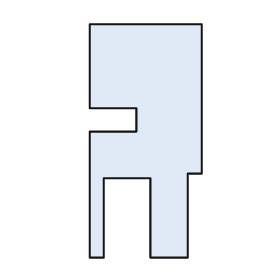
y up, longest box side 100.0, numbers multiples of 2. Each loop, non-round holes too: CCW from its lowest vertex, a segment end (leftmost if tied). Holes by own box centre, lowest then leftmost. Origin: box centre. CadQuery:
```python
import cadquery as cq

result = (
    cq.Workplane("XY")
    .moveTo(-24.0, -50.0)
    .lineTo(-18.0, -50.0)
    .lineTo(-18.0, -16.0)
    .lineTo(2.0, -16.0)
    .lineTo(2.0, -50.0)
    .lineTo(18.0, -50.0)
    .lineTo(18.0, -14.0)
    .lineTo(24.0, -14.0)
    .lineTo(24.0, 50.0)
    .lineTo(-24.0, 50.0)
    .lineTo(-24.0, 14.0)
    .lineTo(-4.0, 14.0)
    .lineTo(-4.0, 4.0)
    .lineTo(-24.0, 4.0)
    .close()
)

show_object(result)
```